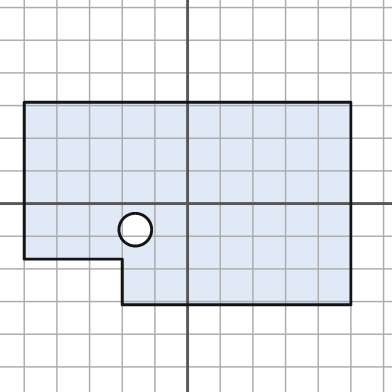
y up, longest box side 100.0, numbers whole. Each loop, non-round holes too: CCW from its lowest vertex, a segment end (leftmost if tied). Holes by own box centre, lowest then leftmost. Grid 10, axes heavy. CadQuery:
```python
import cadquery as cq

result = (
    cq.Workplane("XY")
    .moveTo(-20.0, -31.0)
    .lineTo(50.0, -31.0)
    .lineTo(50.0, 31.0)
    .lineTo(-50.0, 31.0)
    .lineTo(-50.0, -17.0)
    .lineTo(-20.0, -17.0)
    .close()
    .moveTo(-16.0, -8.0)
    .circle(5.0)
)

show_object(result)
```